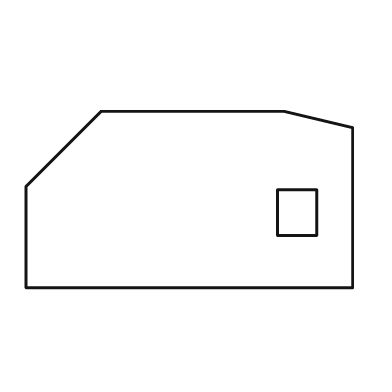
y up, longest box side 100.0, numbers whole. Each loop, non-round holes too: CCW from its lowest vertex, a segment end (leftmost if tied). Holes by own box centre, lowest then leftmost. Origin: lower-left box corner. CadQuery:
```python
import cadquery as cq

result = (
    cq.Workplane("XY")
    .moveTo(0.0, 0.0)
    .lineTo(100.0, 0.0)
    .lineTo(100.0, 49.0)
    .lineTo(79.0, 54.0)
    .lineTo(23.0, 54.0)
    .lineTo(0.0, 31.0)
    .close()
    .moveTo(77.0, 16.0)
    .lineTo(89.0, 16.0)
    .lineTo(89.0, 30.0)
    .lineTo(77.0, 30.0)
    .close()
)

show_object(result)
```